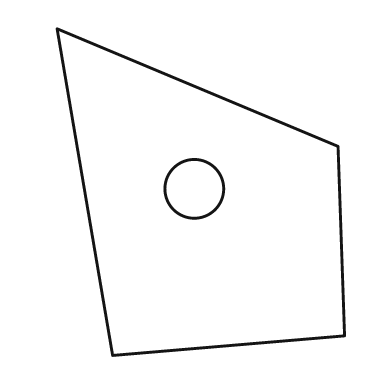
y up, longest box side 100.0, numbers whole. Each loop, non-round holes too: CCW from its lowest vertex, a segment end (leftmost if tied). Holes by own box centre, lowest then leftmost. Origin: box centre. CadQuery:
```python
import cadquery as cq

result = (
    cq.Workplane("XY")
    .moveTo(-27.0, -50.0)
    .lineTo(44.0, -44.0)
    .lineTo(42.0, 14.0)
    .lineTo(-44.0, 50.0)
    .close()
    .moveTo(-2.0, 1.0)
    .circle(9.0)
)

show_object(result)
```